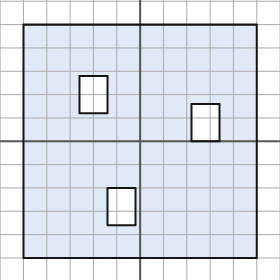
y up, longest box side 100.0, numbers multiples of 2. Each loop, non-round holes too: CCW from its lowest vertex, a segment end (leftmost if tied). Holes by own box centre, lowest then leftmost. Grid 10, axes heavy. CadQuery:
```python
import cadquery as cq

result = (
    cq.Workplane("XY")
    .moveTo(-50.0, -50.0)
    .lineTo(50.0, -50.0)
    .lineTo(50.0, 50.0)
    .lineTo(-50.0, 50.0)
    .close()
    .moveTo(-14.0, -36.0)
    .lineTo(-2.0, -36.0)
    .lineTo(-2.0, -20.0)
    .lineTo(-14.0, -20.0)
    .close()
    .moveTo(22.0, 0.0)
    .lineTo(34.0, 0.0)
    .lineTo(34.0, 16.0)
    .lineTo(22.0, 16.0)
    .close()
    .moveTo(-26.0, 12.0)
    .lineTo(-14.0, 12.0)
    .lineTo(-14.0, 28.0)
    .lineTo(-26.0, 28.0)
    .close()
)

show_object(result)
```